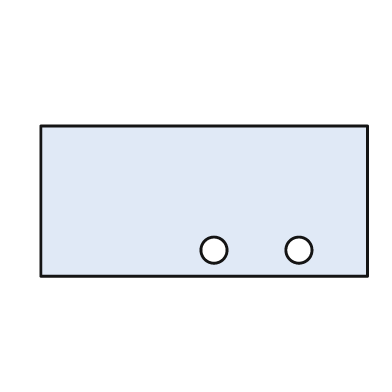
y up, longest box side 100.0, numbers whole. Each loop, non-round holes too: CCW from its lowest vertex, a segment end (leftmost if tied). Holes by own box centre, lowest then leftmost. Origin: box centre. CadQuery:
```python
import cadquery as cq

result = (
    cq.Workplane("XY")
    .moveTo(-50.0, -23.0)
    .lineTo(50.0, -23.0)
    .lineTo(50.0, 23.0)
    .lineTo(-50.0, 23.0)
    .close()
    .moveTo(3.0, -15.0)
    .circle(4.0)
    .moveTo(29.0, -15.0)
    .circle(4.0)
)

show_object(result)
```